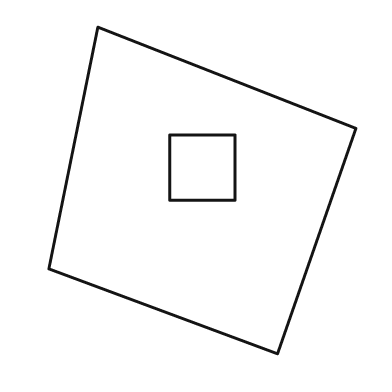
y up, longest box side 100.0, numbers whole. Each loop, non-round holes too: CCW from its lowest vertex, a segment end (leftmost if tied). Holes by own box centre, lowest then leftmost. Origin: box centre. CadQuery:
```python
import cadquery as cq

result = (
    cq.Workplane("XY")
    .moveTo(23.0, -50.0)
    .lineTo(47.0, 19.0)
    .lineTo(-32.0, 50.0)
    .lineTo(-47.0, -24.0)
    .close()
    .moveTo(-10.0, -3.0)
    .lineTo(10.0, -3.0)
    .lineTo(10.0, 17.0)
    .lineTo(-10.0, 17.0)
    .close()
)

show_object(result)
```